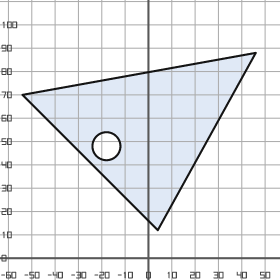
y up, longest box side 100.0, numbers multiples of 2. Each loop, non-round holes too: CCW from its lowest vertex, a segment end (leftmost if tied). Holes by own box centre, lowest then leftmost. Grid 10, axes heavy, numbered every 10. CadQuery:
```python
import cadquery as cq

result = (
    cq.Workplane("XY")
    .moveTo(4.0, 12.0)
    .lineTo(46.0, 88.0)
    .lineTo(-54.0, 70.0)
    .close()
    .moveTo(-18.0, 48.0)
    .circle(6.0)
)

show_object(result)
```